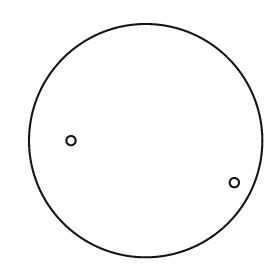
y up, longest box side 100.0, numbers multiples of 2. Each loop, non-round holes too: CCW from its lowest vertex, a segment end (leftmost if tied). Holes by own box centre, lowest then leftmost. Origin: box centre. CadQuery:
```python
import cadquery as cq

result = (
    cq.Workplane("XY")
    .moveTo(0.0, 0.0)
    .circle(50.0)
    .moveTo(38.0, -18.0)
    .circle(2.0)
    .moveTo(-32.0, 0.0)
    .circle(2.0)
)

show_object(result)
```